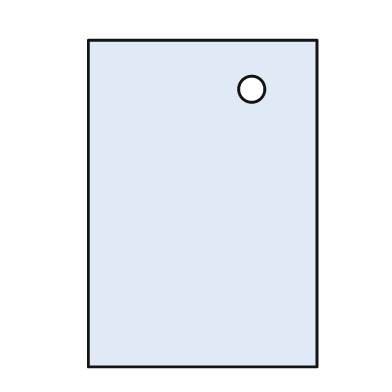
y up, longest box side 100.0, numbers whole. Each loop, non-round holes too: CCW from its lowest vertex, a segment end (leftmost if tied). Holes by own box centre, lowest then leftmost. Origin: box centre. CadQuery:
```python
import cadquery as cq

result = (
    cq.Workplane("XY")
    .moveTo(-35.0, -50.0)
    .lineTo(35.0, -50.0)
    .lineTo(35.0, 50.0)
    .lineTo(-35.0, 50.0)
    .close()
    .moveTo(15.0, 35.0)
    .circle(4.0)
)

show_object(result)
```